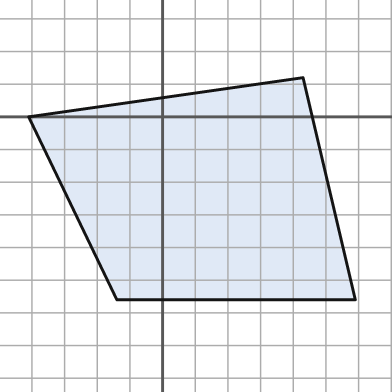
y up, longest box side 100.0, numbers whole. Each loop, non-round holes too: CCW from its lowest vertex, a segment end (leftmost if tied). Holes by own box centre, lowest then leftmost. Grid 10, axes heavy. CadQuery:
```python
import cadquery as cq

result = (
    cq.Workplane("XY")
    .moveTo(-14.0, -56.0)
    .lineTo(59.0, -56.0)
    .lineTo(43.0, 12.0)
    .lineTo(-41.0, 0.0)
    .close()
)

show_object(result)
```